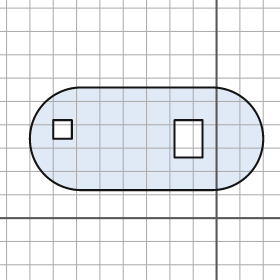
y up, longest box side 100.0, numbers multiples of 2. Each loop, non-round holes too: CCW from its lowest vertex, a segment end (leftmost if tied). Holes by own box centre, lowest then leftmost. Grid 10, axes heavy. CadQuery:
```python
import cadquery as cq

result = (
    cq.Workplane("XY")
    .moveTo(-58.0, 12.0)
    .lineTo(-2.0, 12.0)
    .threePointArc((20.0, 34.0), (-2.0, 56.0))
    .lineTo(-58.0, 56.0)
    .threePointArc((-80.0, 34.0), (-58.0, 12.0))
    .close()
    .moveTo(-18.0, 26.0)
    .lineTo(-6.0, 26.0)
    .lineTo(-6.0, 42.0)
    .lineTo(-18.0, 42.0)
    .close()
    .moveTo(-70.0, 34.0)
    .lineTo(-62.0, 34.0)
    .lineTo(-62.0, 42.0)
    .lineTo(-70.0, 42.0)
    .close()
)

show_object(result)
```